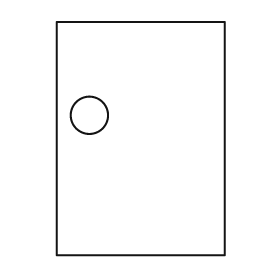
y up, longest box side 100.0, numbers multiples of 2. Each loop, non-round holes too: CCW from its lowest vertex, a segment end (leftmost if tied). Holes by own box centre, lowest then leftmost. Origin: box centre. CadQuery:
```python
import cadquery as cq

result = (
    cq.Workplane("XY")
    .moveTo(-36.0, -50.0)
    .lineTo(36.0, -50.0)
    .lineTo(36.0, 50.0)
    .lineTo(-36.0, 50.0)
    .close()
    .moveTo(-22.0, 10.0)
    .circle(8.0)
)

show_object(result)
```